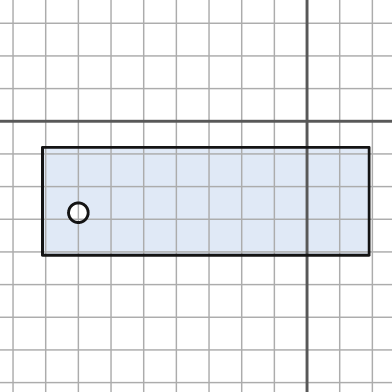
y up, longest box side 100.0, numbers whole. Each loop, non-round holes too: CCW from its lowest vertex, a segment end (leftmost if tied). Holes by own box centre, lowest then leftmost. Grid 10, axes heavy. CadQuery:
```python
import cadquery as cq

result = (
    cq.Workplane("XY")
    .moveTo(-81.0, -41.0)
    .lineTo(19.0, -41.0)
    .lineTo(19.0, -8.0)
    .lineTo(-81.0, -8.0)
    .close()
    .moveTo(-70.0, -28.0)
    .circle(3.0)
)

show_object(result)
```